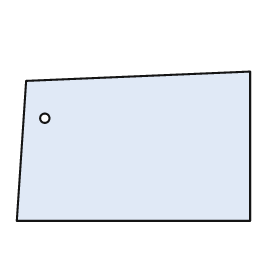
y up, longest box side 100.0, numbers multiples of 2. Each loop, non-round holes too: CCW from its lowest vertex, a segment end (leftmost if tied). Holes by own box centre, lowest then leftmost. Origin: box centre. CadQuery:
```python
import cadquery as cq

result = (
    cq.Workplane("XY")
    .moveTo(-50.0, -32.0)
    .lineTo(50.0, -32.0)
    .lineTo(50.0, 32.0)
    .lineTo(-46.0, 28.0)
    .close()
    .moveTo(-38.0, 12.0)
    .circle(2.0)
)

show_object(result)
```